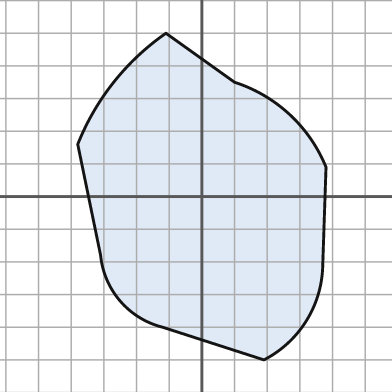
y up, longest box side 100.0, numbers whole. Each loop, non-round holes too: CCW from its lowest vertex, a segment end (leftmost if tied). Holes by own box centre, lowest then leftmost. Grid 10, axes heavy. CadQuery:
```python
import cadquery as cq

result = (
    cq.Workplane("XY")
    .moveTo(19.0, -50.0)
    .threePointArc((32.0, -38.0), (37.0, -21.0))
    .lineTo(38.0, 9.0)
    .threePointArc((27.0, 25.0), (10.0, 35.0))
    .lineTo(-11.0, 50.0)
    .threePointArc((-27.0, 35.0), (-38.0, 16.0))
    .lineTo(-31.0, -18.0)
    .threePointArc((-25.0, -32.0), (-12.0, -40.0))
    .close()
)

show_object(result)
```